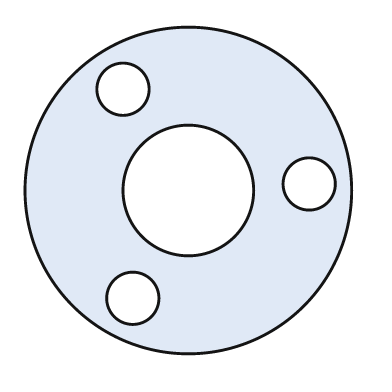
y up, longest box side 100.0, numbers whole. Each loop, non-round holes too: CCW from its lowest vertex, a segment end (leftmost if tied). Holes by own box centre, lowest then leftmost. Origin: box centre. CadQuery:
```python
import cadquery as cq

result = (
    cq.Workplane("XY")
    .moveTo(0.0, 0.0)
    .circle(50.0)
    .moveTo(-17.0, -33.0)
    .circle(8.0)
    .moveTo(0.0, 0.0)
    .circle(20.0)
    .moveTo(37.0, 2.0)
    .circle(8.0)
    .moveTo(-20.0, 31.0)
    .circle(8.0)
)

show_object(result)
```